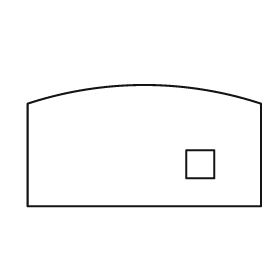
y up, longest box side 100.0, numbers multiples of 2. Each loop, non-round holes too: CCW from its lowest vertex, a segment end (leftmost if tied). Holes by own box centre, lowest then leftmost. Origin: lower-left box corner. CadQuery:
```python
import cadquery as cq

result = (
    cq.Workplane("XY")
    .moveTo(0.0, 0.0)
    .lineTo(100.0, 0.0)
    .lineTo(100.0, 44.0)
    .threePointArc((50.0, 52.0), (0.0, 44.0))
    .close()
    .moveTo(68.0, 12.0)
    .lineTo(80.0, 12.0)
    .lineTo(80.0, 24.0)
    .lineTo(68.0, 24.0)
    .close()
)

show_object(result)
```